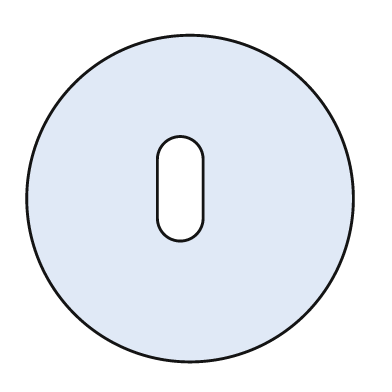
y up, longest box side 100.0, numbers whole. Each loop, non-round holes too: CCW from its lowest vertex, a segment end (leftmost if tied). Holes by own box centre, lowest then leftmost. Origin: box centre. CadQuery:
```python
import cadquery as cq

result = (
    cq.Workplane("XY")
    .moveTo(0.0, 0.0)
    .circle(50.0)
    .moveTo(-10.0, -6.0)
    .threePointArc((-3.0, -13.0), (4.0, -6.0))
    .lineTo(4.0, 12.0)
    .threePointArc((-3.0, 19.0), (-10.0, 12.0))
    .close()
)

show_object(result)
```